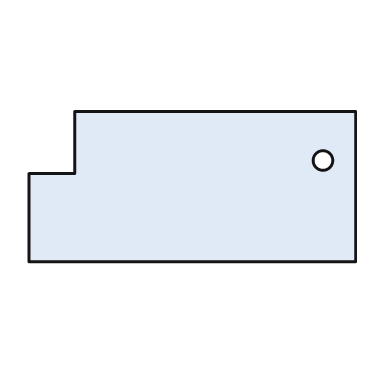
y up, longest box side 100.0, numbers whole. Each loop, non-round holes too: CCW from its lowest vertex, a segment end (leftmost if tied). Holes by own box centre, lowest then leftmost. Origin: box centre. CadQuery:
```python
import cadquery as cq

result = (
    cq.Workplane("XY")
    .moveTo(-50.0, -23.0)
    .lineTo(50.0, -23.0)
    .lineTo(50.0, 23.0)
    .lineTo(-36.0, 23.0)
    .lineTo(-36.0, 4.0)
    .lineTo(-50.0, 4.0)
    .close()
    .moveTo(40.0, 8.0)
    .circle(3.0)
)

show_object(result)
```